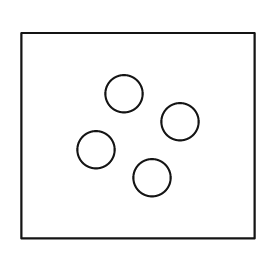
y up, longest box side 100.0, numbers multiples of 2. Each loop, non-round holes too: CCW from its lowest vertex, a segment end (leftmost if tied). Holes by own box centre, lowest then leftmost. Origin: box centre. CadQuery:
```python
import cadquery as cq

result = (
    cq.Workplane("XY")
    .moveTo(-50.0, -44.0)
    .lineTo(50.0, -44.0)
    .lineTo(50.0, 44.0)
    .lineTo(-50.0, 44.0)
    .close()
    .moveTo(6.0, -18.0)
    .circle(8.0)
    .moveTo(-18.0, -6.0)
    .circle(8.0)
    .moveTo(18.0, 6.0)
    .circle(8.0)
    .moveTo(-6.0, 18.0)
    .circle(8.0)
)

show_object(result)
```